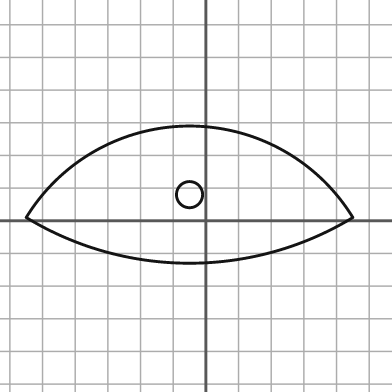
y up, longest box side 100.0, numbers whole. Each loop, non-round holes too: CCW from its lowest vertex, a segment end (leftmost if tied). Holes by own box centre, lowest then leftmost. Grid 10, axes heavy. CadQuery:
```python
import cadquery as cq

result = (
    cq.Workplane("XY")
    .moveTo(-55.0, 1.0)
    .threePointArc((-5.0, -13.0), (45.0, 1.0))
    .threePointArc((-5.0, 29.0), (-55.0, 1.0))
    .close()
    .moveTo(-5.0, 8.0)
    .circle(4.0)
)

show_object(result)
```